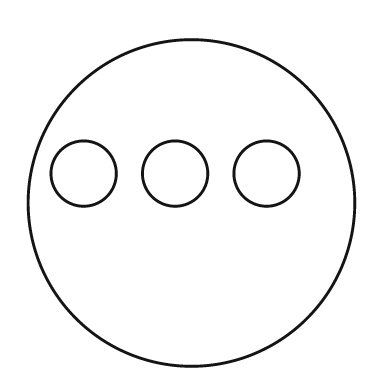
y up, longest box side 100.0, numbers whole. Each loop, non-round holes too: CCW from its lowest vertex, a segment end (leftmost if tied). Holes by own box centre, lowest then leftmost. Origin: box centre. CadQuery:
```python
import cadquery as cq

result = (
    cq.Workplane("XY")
    .moveTo(0.0, 0.0)
    .circle(50.0)
    .moveTo(-33.0, 9.0)
    .circle(10.0)
    .moveTo(-5.0, 9.0)
    .circle(10.0)
    .moveTo(23.0, 9.0)
    .circle(10.0)
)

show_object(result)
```